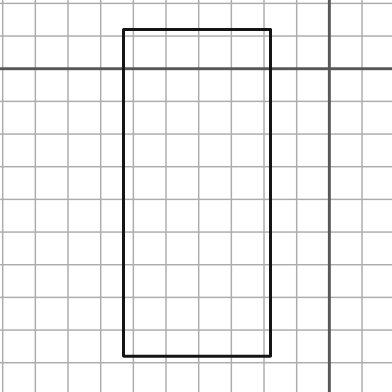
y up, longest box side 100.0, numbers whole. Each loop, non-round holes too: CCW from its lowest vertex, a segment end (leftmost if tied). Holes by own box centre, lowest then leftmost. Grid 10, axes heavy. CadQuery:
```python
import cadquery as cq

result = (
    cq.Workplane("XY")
    .moveTo(-63.0, -88.0)
    .lineTo(-18.0, -88.0)
    .lineTo(-18.0, 12.0)
    .lineTo(-63.0, 12.0)
    .close()
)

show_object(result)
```